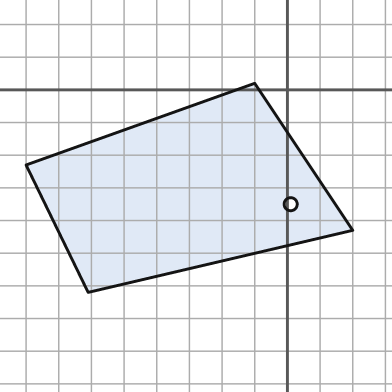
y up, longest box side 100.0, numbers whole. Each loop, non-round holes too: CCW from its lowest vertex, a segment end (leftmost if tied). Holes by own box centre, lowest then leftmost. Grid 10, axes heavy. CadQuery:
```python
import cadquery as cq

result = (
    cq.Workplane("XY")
    .moveTo(-61.0, -62.0)
    .lineTo(20.0, -43.0)
    .lineTo(-10.0, 2.0)
    .lineTo(-80.0, -23.0)
    .close()
    .moveTo(1.0, -35.0)
    .circle(2.0)
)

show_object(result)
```